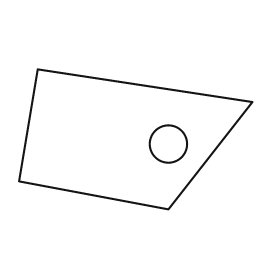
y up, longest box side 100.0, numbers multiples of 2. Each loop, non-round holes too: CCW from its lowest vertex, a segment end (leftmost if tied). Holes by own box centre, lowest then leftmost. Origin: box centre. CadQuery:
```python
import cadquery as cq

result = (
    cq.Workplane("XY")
    .moveTo(14.0, -30.0)
    .lineTo(50.0, 16.0)
    .lineTo(-42.0, 30.0)
    .lineTo(-50.0, -18.0)
    .close()
    .moveTo(14.0, -2.0)
    .circle(8.0)
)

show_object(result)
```